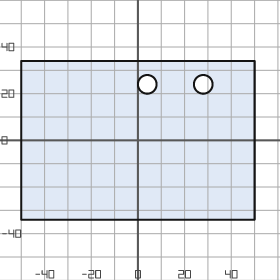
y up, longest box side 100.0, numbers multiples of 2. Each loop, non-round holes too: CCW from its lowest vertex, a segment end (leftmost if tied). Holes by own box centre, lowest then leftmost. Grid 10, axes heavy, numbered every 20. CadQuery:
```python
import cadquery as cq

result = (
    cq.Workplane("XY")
    .moveTo(-50.0, -34.0)
    .lineTo(50.0, -34.0)
    .lineTo(50.0, 34.0)
    .lineTo(-50.0, 34.0)
    .close()
    .moveTo(4.0, 24.0)
    .circle(4.0)
    .moveTo(28.0, 24.0)
    .circle(4.0)
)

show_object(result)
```